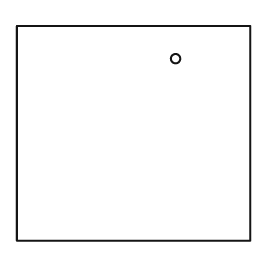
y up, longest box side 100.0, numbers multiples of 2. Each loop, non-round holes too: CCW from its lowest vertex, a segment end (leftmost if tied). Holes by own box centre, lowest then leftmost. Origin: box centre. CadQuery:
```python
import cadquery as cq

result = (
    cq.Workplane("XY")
    .moveTo(-50.0, -46.0)
    .lineTo(50.0, -46.0)
    .lineTo(50.0, 46.0)
    .lineTo(-50.0, 46.0)
    .close()
    .moveTo(18.0, 32.0)
    .circle(2.0)
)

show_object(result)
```